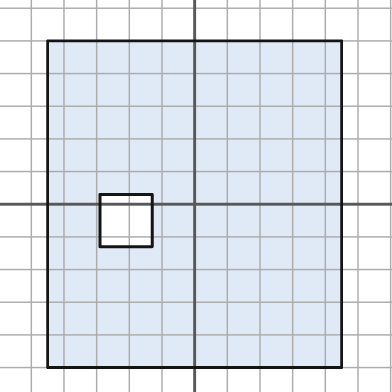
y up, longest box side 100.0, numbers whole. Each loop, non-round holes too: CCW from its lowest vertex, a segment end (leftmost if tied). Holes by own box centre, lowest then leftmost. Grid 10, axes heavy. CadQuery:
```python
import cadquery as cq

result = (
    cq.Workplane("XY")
    .moveTo(-45.0, -50.0)
    .lineTo(45.0, -50.0)
    .lineTo(45.0, 50.0)
    .lineTo(-45.0, 50.0)
    .close()
    .moveTo(-29.0, -13.0)
    .lineTo(-13.0, -13.0)
    .lineTo(-13.0, 3.0)
    .lineTo(-29.0, 3.0)
    .close()
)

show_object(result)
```